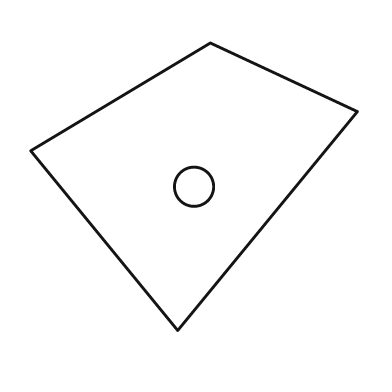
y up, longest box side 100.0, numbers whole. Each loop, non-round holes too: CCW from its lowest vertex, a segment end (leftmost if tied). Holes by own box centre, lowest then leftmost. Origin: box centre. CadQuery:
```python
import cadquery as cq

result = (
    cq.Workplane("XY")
    .moveTo(-5.0, -44.0)
    .lineTo(50.0, 23.0)
    .lineTo(5.0, 44.0)
    .lineTo(-50.0, 11.0)
    .close()
    .moveTo(0.0, 0.0)
    .circle(6.0)
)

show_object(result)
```